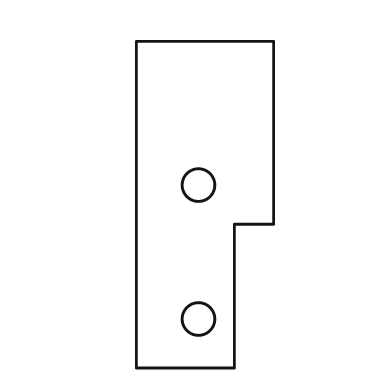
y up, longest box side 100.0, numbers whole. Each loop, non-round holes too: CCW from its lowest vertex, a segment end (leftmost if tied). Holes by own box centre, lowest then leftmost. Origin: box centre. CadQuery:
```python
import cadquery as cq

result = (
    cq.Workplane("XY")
    .moveTo(-21.0, -50.0)
    .lineTo(9.0, -50.0)
    .lineTo(9.0, -6.0)
    .lineTo(21.0, -6.0)
    .lineTo(21.0, 50.0)
    .lineTo(-21.0, 50.0)
    .close()
    .moveTo(-2.0, -35.0)
    .circle(5.0)
    .moveTo(-2.0, 6.0)
    .circle(5.0)
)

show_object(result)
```